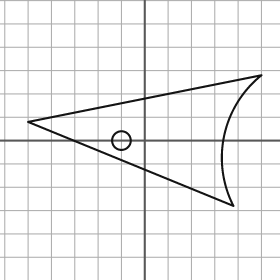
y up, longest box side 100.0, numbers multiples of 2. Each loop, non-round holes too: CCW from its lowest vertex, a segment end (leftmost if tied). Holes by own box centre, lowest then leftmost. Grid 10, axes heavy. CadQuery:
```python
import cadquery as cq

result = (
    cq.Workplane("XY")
    .moveTo(38.0, -28.0)
    .threePointArc((34.0, 2.0), (50.0, 28.0))
    .lineTo(-50.0, 8.0)
    .close()
    .moveTo(-10.0, 0.0)
    .circle(4.0)
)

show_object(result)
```